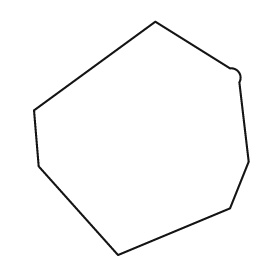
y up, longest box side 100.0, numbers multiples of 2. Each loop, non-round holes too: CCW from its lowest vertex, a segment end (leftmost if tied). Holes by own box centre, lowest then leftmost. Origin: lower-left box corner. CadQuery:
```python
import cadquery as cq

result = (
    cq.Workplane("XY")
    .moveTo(36.0, 0.0)
    .lineTo(84.0, 20.0)
    .lineTo(92.0, 40.0)
    .lineTo(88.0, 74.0)
    .threePointArc((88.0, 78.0), (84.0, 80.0))
    .lineTo(52.0, 100.0)
    .lineTo(0.0, 62.0)
    .lineTo(2.0, 38.0)
    .close()
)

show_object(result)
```